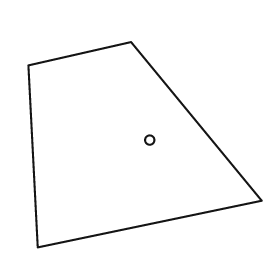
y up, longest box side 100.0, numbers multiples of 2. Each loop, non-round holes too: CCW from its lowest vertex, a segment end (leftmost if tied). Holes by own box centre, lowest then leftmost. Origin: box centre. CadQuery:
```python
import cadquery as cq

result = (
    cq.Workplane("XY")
    .moveTo(-46.0, -44.0)
    .lineTo(50.0, -24.0)
    .lineTo(-6.0, 44.0)
    .lineTo(-50.0, 34.0)
    .close()
    .moveTo(2.0, 2.0)
    .circle(2.0)
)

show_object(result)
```